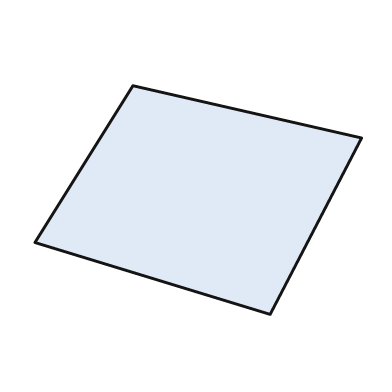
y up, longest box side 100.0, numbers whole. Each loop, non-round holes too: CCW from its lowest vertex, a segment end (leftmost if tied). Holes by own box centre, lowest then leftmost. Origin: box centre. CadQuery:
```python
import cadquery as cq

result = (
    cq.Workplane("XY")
    .moveTo(22.0, -35.0)
    .lineTo(50.0, 19.0)
    .lineTo(-20.0, 35.0)
    .lineTo(-50.0, -13.0)
    .close()
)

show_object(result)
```